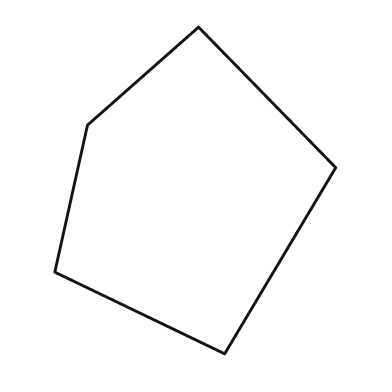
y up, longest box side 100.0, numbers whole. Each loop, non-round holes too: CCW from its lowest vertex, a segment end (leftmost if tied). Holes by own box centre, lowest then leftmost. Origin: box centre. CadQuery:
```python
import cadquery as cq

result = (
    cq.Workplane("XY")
    .moveTo(9.0, -50.0)
    .lineTo(43.0, 7.0)
    .lineTo(1.0, 50.0)
    .lineTo(-33.0, 20.0)
    .lineTo(-43.0, -25.0)
    .close()
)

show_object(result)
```